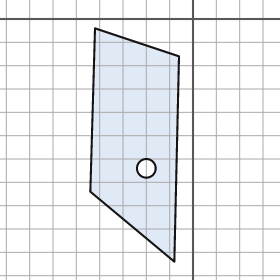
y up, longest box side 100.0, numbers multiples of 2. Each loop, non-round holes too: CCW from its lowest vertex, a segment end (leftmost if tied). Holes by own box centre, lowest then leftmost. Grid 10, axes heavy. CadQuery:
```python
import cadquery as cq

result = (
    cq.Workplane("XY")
    .moveTo(-8.0, -104.0)
    .lineTo(-6.0, -16.0)
    .lineTo(-42.0, -4.0)
    .lineTo(-44.0, -74.0)
    .close()
    .moveTo(-20.0, -64.0)
    .circle(4.0)
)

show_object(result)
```